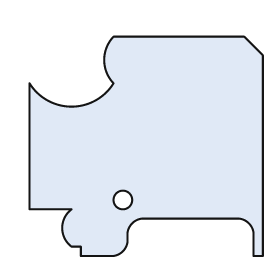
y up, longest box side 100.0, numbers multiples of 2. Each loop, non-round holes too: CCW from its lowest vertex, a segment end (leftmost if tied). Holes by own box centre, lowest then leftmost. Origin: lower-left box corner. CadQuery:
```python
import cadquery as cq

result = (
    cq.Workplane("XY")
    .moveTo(22.0, 0.0)
    .lineTo(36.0, 0.0)
    .threePointArc((40.0, 2.0), (42.0, 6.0))
    .lineTo(42.0, 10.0)
    .threePointArc((44.0, 14.0), (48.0, 16.0))
    .lineTo(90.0, 16.0)
    .threePointArc((94.0, 14.0), (96.0, 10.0))
    .lineTo(96.0, 0.0)
    .lineTo(100.0, 0.0)
    .lineTo(100.0, 86.0)
    .lineTo(92.0, 94.0)
    .lineTo(36.0, 94.0)
    .threePointArc((32.0, 84.0), (36.0, 74.0))
    .threePointArc((18.0, 64.0), (0.0, 74.0))
    .lineTo(0.0, 20.0)
    .lineTo(18.0, 20.0)
    .threePointArc((14.0, 12.0), (18.0, 4.0))
    .lineTo(22.0, 4.0)
    .close()
    .moveTo(40.0, 24.0)
    .circle(4.0)
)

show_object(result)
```